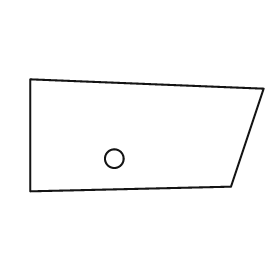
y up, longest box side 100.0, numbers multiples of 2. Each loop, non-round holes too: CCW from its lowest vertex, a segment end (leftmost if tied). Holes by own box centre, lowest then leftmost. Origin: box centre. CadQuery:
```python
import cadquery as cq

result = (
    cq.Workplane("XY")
    .moveTo(-50.0, -24.0)
    .lineTo(36.0, -22.0)
    .lineTo(50.0, 20.0)
    .lineTo(-50.0, 24.0)
    .close()
    .moveTo(-14.0, -10.0)
    .circle(4.0)
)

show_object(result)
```